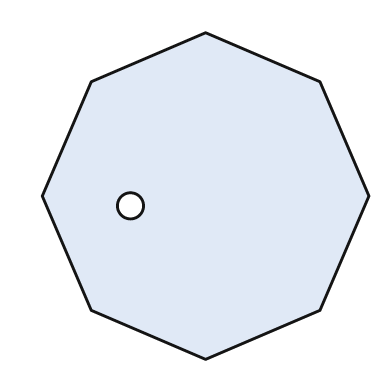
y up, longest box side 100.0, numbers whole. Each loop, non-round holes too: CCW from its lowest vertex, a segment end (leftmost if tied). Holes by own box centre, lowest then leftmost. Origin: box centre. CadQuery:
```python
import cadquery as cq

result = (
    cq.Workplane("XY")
    .moveTo(0.0, -50.0)
    .lineTo(35.0, -35.0)
    .lineTo(50.0, 0.0)
    .lineTo(35.0, 35.0)
    .lineTo(0.0, 50.0)
    .lineTo(-35.0, 35.0)
    .lineTo(-50.0, 0.0)
    .lineTo(-35.0, -35.0)
    .close()
    .moveTo(-23.0, -3.0)
    .circle(4.0)
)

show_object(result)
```